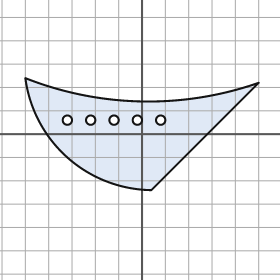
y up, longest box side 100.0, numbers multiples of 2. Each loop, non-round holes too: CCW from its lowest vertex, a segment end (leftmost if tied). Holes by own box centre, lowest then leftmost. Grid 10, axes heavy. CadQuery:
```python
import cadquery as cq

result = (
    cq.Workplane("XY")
    .moveTo(4.0, -24.0)
    .lineTo(50.0, 22.0)
    .threePointArc((0.0, 14.0), (-50.0, 24.0))
    .threePointArc((-32.0, -10.0), (4.0, -24.0))
    .close()
    .moveTo(-32.0, 6.0)
    .circle(2.0)
    .moveTo(-22.0, 6.0)
    .circle(2.0)
    .moveTo(-12.0, 6.0)
    .circle(2.0)
    .moveTo(-2.0, 6.0)
    .circle(2.0)
    .moveTo(8.0, 6.0)
    .circle(2.0)
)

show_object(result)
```